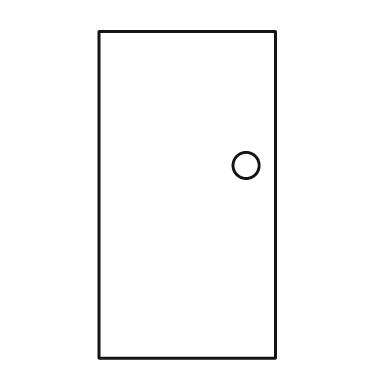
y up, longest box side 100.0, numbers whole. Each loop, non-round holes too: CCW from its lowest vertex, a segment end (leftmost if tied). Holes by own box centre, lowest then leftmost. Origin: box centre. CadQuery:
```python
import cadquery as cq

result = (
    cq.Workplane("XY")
    .moveTo(-27.0, -50.0)
    .lineTo(27.0, -50.0)
    .lineTo(27.0, 50.0)
    .lineTo(-27.0, 50.0)
    .close()
    .moveTo(18.0, 9.0)
    .circle(4.0)
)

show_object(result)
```